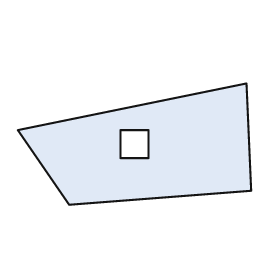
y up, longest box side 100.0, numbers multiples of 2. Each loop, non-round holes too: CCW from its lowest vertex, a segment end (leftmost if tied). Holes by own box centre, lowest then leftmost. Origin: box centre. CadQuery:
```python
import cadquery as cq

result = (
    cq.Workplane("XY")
    .moveTo(-28.0, -26.0)
    .lineTo(50.0, -20.0)
    .lineTo(48.0, 26.0)
    .lineTo(-50.0, 6.0)
    .close()
    .moveTo(-6.0, -6.0)
    .lineTo(6.0, -6.0)
    .lineTo(6.0, 6.0)
    .lineTo(-6.0, 6.0)
    .close()
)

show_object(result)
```